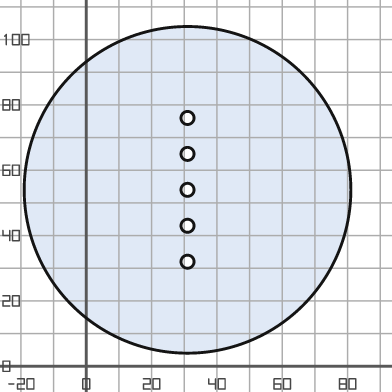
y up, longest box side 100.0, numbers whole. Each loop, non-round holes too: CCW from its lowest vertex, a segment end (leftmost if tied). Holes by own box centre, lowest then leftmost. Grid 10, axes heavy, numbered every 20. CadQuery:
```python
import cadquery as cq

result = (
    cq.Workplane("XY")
    .moveTo(31.0, 54.0)
    .circle(50.0)
    .moveTo(31.0, 32.0)
    .circle(2.0)
    .moveTo(31.0, 43.0)
    .circle(2.0)
    .moveTo(31.0, 54.0)
    .circle(2.0)
    .moveTo(31.0, 65.0)
    .circle(2.0)
    .moveTo(31.0, 76.0)
    .circle(2.0)
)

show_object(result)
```